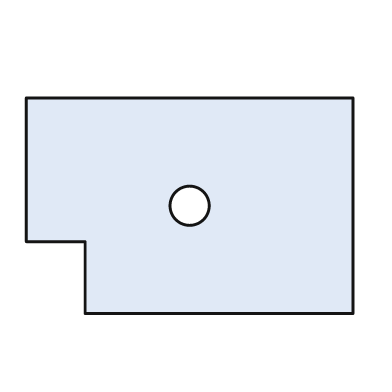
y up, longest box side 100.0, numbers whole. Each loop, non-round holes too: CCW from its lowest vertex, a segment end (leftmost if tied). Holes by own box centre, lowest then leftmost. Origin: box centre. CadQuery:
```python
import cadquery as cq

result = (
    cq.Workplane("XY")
    .moveTo(-32.0, -33.0)
    .lineTo(50.0, -33.0)
    .lineTo(50.0, 33.0)
    .lineTo(-50.0, 33.0)
    .lineTo(-50.0, -11.0)
    .lineTo(-32.0, -11.0)
    .close()
    .moveTo(0.0, 0.0)
    .circle(6.0)
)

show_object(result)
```